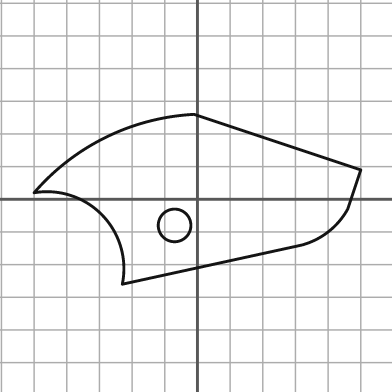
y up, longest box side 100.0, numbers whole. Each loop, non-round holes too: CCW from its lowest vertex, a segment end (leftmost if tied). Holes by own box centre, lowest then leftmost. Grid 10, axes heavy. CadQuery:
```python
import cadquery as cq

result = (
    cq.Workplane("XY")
    .moveTo(-23.0, -26.0)
    .lineTo(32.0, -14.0)
    .threePointArc((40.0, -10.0), (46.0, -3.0))
    .lineTo(50.0, 9.0)
    .lineTo(-1.0, 26.0)
    .threePointArc((-28.0, 19.0), (-50.0, 2.0))
    .threePointArc((-29.0, -5.0), (-23.0, -26.0))
    .close()
    .moveTo(-7.0, -8.0)
    .circle(5.0)
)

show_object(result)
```